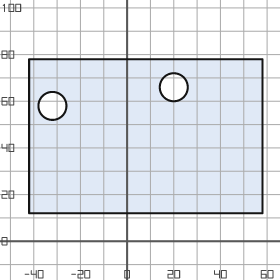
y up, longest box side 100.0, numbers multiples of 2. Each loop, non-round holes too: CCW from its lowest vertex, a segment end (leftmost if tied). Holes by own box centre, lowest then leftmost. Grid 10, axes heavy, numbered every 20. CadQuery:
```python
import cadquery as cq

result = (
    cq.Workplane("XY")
    .moveTo(-42.0, 12.0)
    .lineTo(58.0, 12.0)
    .lineTo(58.0, 78.0)
    .lineTo(-42.0, 78.0)
    .close()
    .moveTo(-32.0, 58.0)
    .circle(6.0)
    .moveTo(20.0, 66.0)
    .circle(6.0)
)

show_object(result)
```